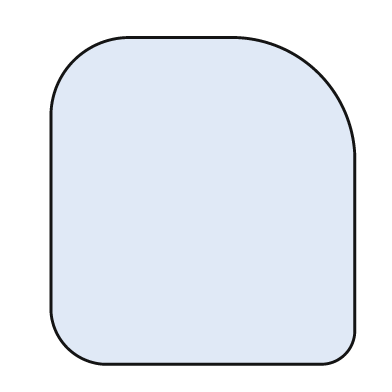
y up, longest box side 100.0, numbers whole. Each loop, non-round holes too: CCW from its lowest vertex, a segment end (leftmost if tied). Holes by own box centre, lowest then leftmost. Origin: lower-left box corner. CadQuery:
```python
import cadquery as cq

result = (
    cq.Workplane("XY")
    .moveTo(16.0, 0.0)
    .lineTo(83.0, 0.0)
    .threePointArc((90.0, 3.0), (93.0, 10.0))
    .lineTo(93.0, 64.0)
    .threePointArc((82.0, 89.0), (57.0, 100.0))
    .lineTo(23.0, 100.0)
    .threePointArc((7.0, 93.0), (0.0, 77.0))
    .lineTo(0.0, 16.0)
    .threePointArc((5.0, 5.0), (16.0, 0.0))
    .close()
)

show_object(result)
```